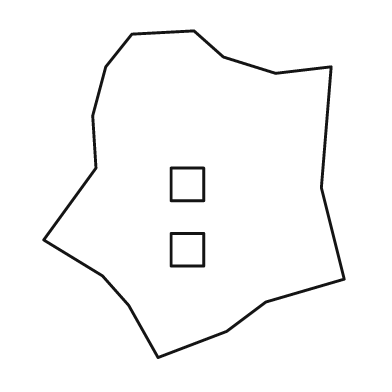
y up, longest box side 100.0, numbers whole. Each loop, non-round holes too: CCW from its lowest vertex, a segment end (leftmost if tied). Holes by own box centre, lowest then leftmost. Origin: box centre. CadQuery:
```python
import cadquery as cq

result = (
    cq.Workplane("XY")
    .moveTo(-11.0, -50.0)
    .lineTo(10.0, -42.0)
    .lineTo(22.0, -33.0)
    .lineTo(46.0, -26.0)
    .lineTo(39.0, 2.0)
    .lineTo(42.0, 39.0)
    .lineTo(25.0, 37.0)
    .lineTo(9.0, 42.0)
    .lineTo(0.0, 50.0)
    .lineTo(-19.0, 49.0)
    .lineTo(-27.0, 39.0)
    .lineTo(-31.0, 24.0)
    .lineTo(-30.0, 8.0)
    .lineTo(-46.0, -14.0)
    .lineTo(-28.0, -25.0)
    .lineTo(-20.0, -34.0)
    .close()
    .moveTo(-7.0, -22.0)
    .lineTo(3.0, -22.0)
    .lineTo(3.0, -12.0)
    .lineTo(-7.0, -12.0)
    .close()
    .moveTo(-7.0, -2.0)
    .lineTo(3.0, -2.0)
    .lineTo(3.0, 8.0)
    .lineTo(-7.0, 8.0)
    .close()
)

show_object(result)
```